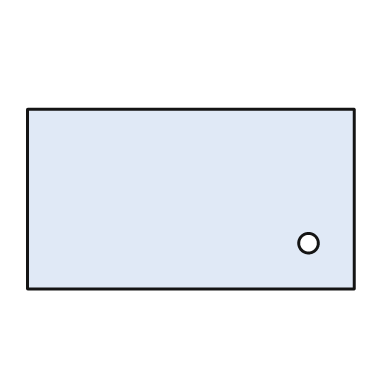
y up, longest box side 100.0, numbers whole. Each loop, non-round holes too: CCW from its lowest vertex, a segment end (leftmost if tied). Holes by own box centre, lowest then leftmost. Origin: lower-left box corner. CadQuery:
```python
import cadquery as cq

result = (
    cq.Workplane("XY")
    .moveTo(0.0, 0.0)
    .lineTo(100.0, 0.0)
    .lineTo(100.0, 55.0)
    .lineTo(0.0, 55.0)
    .close()
    .moveTo(86.0, 14.0)
    .circle(3.0)
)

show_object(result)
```